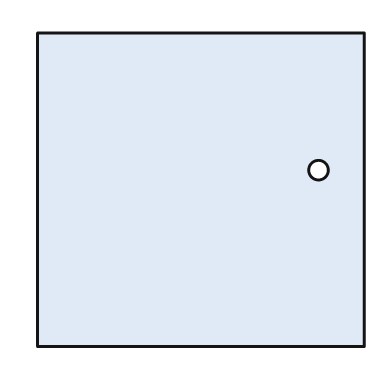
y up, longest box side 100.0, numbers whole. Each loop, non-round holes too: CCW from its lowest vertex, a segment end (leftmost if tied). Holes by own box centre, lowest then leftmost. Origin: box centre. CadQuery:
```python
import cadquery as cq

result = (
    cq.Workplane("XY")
    .moveTo(-50.0, -48.0)
    .lineTo(50.0, -48.0)
    .lineTo(50.0, 48.0)
    .lineTo(-50.0, 48.0)
    .close()
    .moveTo(36.0, 6.0)
    .circle(3.0)
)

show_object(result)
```